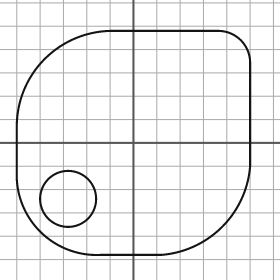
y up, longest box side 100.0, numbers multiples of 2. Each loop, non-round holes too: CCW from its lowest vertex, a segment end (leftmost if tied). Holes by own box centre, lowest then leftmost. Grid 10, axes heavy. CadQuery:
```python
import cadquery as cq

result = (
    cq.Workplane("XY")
    .moveTo(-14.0, -48.0)
    .lineTo(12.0, -48.0)
    .threePointArc((38.0, -36.0), (50.0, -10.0))
    .lineTo(50.0, 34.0)
    .threePointArc((46.0, 44.0), (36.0, 48.0))
    .lineTo(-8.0, 48.0)
    .threePointArc((-38.0, 36.0), (-50.0, 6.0))
    .lineTo(-50.0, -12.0)
    .threePointArc((-40.0, -38.0), (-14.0, -48.0))
    .close()
    .moveTo(-28.0, -24.0)
    .circle(12.0)
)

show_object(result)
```